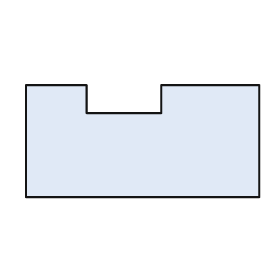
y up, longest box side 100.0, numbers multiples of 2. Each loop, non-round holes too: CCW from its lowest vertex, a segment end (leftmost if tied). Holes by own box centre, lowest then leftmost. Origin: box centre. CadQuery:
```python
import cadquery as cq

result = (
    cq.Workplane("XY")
    .moveTo(-50.0, -24.0)
    .lineTo(50.0, -24.0)
    .lineTo(50.0, 24.0)
    .lineTo(8.0, 24.0)
    .lineTo(8.0, 12.0)
    .lineTo(-24.0, 12.0)
    .lineTo(-24.0, 24.0)
    .lineTo(-50.0, 24.0)
    .close()
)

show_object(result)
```